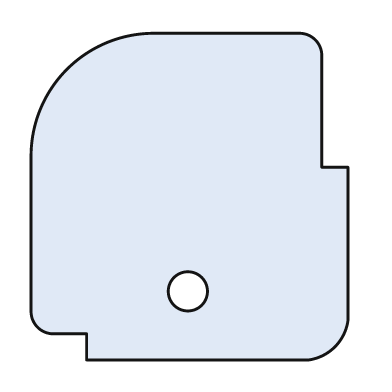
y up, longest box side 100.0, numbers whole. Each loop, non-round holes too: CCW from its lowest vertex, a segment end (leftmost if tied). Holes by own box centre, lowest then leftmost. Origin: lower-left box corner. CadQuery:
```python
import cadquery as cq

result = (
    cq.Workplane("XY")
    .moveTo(17.0, 0.0)
    .lineTo(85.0, 0.0)
    .threePointArc((93.0, 4.0), (97.0, 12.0))
    .lineTo(97.0, 59.0)
    .lineTo(89.0, 59.0)
    .lineTo(89.0, 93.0)
    .threePointArc((87.0, 98.0), (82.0, 100.0))
    .lineTo(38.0, 100.0)
    .threePointArc((11.0, 89.0), (0.0, 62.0))
    .lineTo(0.0, 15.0)
    .threePointArc((2.0, 10.0), (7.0, 8.0))
    .lineTo(17.0, 8.0)
    .close()
    .moveTo(48.0, 21.0)
    .circle(6.0)
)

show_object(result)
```